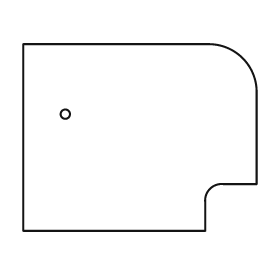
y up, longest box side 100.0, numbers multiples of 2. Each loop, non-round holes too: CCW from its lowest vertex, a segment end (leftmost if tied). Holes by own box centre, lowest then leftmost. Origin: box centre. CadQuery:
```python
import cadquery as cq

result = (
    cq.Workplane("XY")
    .moveTo(-50.0, -40.0)
    .lineTo(28.0, -40.0)
    .lineTo(28.0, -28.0)
    .threePointArc((30.0, -22.0), (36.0, -20.0))
    .lineTo(50.0, -20.0)
    .lineTo(50.0, 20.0)
    .threePointArc((44.0, 34.0), (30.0, 40.0))
    .lineTo(-50.0, 40.0)
    .close()
    .moveTo(-32.0, 10.0)
    .circle(2.0)
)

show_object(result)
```